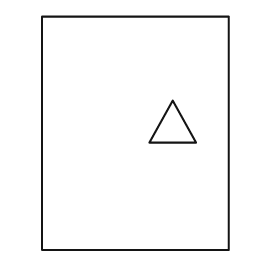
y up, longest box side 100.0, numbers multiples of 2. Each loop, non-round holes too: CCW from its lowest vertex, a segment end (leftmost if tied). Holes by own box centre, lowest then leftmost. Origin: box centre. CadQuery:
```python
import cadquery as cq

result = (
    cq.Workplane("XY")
    .moveTo(-40.0, -50.0)
    .lineTo(40.0, -50.0)
    .lineTo(40.0, 50.0)
    .lineTo(-40.0, 50.0)
    .close()
    .moveTo(6.0, -4.0)
    .lineTo(26.0, -4.0)
    .lineTo(16.0, 14.0)
    .close()
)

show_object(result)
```